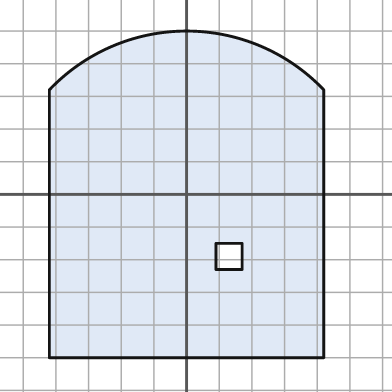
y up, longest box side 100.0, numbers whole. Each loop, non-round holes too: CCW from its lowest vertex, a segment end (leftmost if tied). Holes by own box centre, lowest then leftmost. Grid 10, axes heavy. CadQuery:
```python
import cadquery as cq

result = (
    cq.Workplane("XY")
    .moveTo(-42.0, -50.0)
    .lineTo(42.0, -50.0)
    .lineTo(42.0, 32.0)
    .threePointArc((0.0, 50.0), (-42.0, 32.0))
    .close()
    .moveTo(9.0, -23.0)
    .lineTo(17.0, -23.0)
    .lineTo(17.0, -15.0)
    .lineTo(9.0, -15.0)
    .close()
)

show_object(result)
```